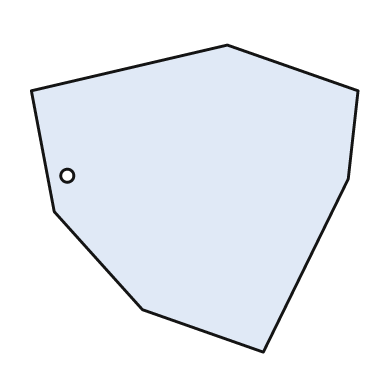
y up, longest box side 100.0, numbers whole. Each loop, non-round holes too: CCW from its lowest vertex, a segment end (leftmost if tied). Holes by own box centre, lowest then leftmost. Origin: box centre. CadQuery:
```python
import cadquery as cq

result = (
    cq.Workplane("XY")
    .moveTo(21.0, -47.0)
    .lineTo(47.0, 6.0)
    .lineTo(50.0, 33.0)
    .lineTo(10.0, 47.0)
    .lineTo(-50.0, 33.0)
    .lineTo(-43.0, -4.0)
    .lineTo(-16.0, -34.0)
    .close()
    .moveTo(-39.0, 7.0)
    .circle(2.0)
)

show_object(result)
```